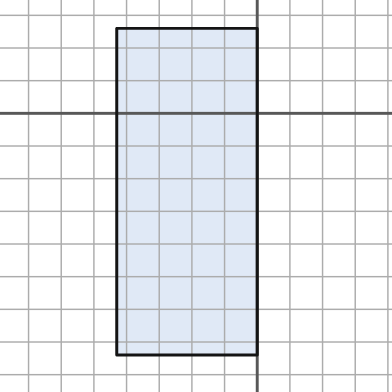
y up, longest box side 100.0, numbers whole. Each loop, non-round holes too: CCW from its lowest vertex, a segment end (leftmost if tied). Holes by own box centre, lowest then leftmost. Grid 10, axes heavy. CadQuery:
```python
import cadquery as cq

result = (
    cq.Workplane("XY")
    .moveTo(-43.0, -74.0)
    .lineTo(0.0, -74.0)
    .lineTo(0.0, 26.0)
    .lineTo(-43.0, 26.0)
    .close()
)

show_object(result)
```